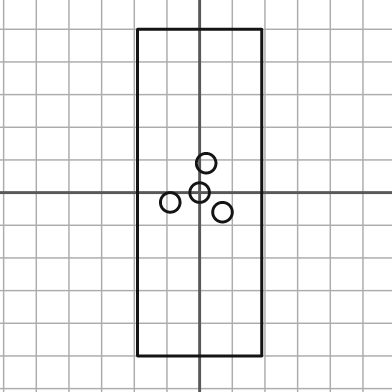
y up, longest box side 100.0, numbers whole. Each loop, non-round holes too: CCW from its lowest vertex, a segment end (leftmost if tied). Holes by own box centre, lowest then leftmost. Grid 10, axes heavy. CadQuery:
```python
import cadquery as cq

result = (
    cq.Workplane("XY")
    .moveTo(-19.0, -50.0)
    .lineTo(19.0, -50.0)
    .lineTo(19.0, 50.0)
    .lineTo(-19.0, 50.0)
    .close()
    .moveTo(7.0, -6.0)
    .circle(3.0)
    .moveTo(-9.0, -3.0)
    .circle(3.0)
    .moveTo(0.0, 0.0)
    .circle(3.0)
    .moveTo(2.0, 9.0)
    .circle(3.0)
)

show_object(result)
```